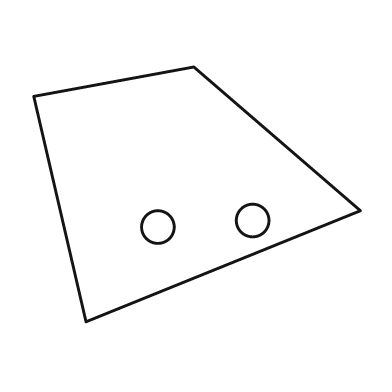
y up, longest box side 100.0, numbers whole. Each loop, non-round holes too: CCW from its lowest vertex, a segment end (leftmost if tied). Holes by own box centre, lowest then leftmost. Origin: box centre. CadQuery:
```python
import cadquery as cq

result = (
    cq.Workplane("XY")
    .moveTo(-34.0, -39.0)
    .lineTo(50.0, -5.0)
    .lineTo(-1.0, 39.0)
    .lineTo(-50.0, 30.0)
    .close()
    .moveTo(-12.0, -10.0)
    .circle(5.0)
    .moveTo(17.0, -8.0)
    .circle(5.0)
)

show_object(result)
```